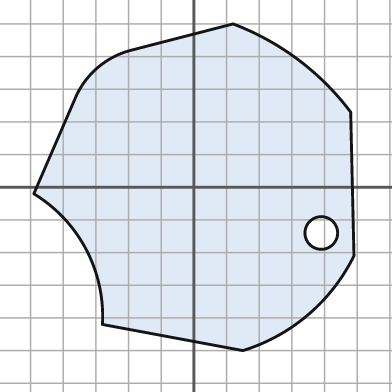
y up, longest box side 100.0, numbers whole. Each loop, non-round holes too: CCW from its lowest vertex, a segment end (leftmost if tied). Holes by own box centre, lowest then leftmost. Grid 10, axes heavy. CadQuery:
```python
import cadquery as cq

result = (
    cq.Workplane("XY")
    .moveTo(15.0, -50.0)
    .threePointArc((35.0, -39.0), (49.0, -21.0))
    .lineTo(48.0, 23.0)
    .threePointArc((32.0, 39.0), (12.0, 50.0))
    .lineTo(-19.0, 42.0)
    .threePointArc((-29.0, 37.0), (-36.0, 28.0))
    .lineTo(-49.0, -2.0)
    .threePointArc((-33.0, -19.0), (-28.0, -42.0))
    .close()
    .moveTo(39.0, -14.0)
    .circle(5.0)
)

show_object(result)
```